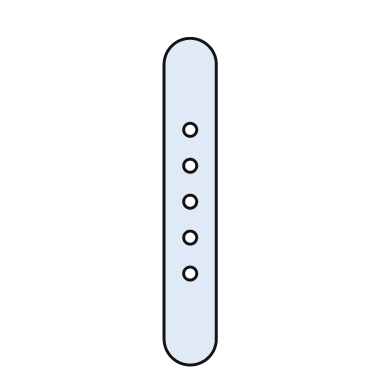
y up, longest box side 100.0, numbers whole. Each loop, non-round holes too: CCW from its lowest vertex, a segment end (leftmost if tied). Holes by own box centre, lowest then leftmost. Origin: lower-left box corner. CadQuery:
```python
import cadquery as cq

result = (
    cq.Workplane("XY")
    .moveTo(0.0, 8.0)
    .threePointArc((8.0, 0.0), (16.0, 8.0))
    .lineTo(16.0, 92.0)
    .threePointArc((8.0, 100.0), (0.0, 92.0))
    .close()
    .moveTo(8.0, 28.0)
    .circle(2.0)
    .moveTo(8.0, 39.0)
    .circle(2.0)
    .moveTo(8.0, 50.0)
    .circle(2.0)
    .moveTo(8.0, 61.0)
    .circle(2.0)
    .moveTo(8.0, 72.0)
    .circle(2.0)
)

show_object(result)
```